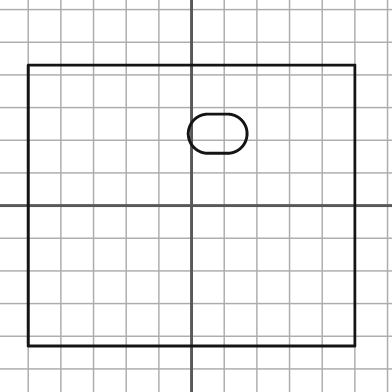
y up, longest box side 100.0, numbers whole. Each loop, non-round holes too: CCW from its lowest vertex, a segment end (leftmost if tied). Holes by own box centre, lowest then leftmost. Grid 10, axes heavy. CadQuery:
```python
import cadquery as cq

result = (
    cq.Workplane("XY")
    .moveTo(-50.0, -43.0)
    .lineTo(50.0, -43.0)
    .lineTo(50.0, 43.0)
    .lineTo(-50.0, 43.0)
    .close()
    .moveTo(5.0, 16.0)
    .lineTo(11.0, 16.0)
    .threePointArc((17.0, 22.0), (11.0, 28.0))
    .lineTo(5.0, 28.0)
    .threePointArc((-1.0, 22.0), (5.0, 16.0))
    .close()
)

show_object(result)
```